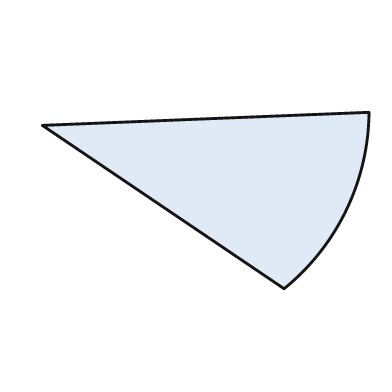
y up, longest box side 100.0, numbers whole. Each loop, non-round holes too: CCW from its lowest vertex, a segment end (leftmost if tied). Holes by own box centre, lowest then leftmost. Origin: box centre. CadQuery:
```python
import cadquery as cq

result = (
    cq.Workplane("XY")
    .moveTo(24.0, -27.0)
    .threePointArc((43.0, -3.0), (50.0, 27.0))
    .lineTo(-50.0, 23.0)
    .close()
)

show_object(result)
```